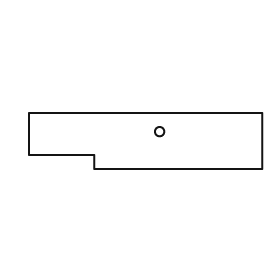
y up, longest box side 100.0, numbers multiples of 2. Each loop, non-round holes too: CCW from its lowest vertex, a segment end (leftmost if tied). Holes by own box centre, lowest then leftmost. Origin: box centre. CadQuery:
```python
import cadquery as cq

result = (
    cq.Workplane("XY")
    .moveTo(-22.0, -12.0)
    .lineTo(50.0, -12.0)
    .lineTo(50.0, 12.0)
    .lineTo(-50.0, 12.0)
    .lineTo(-50.0, -6.0)
    .lineTo(-22.0, -6.0)
    .close()
    .moveTo(6.0, 4.0)
    .circle(2.0)
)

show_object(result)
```